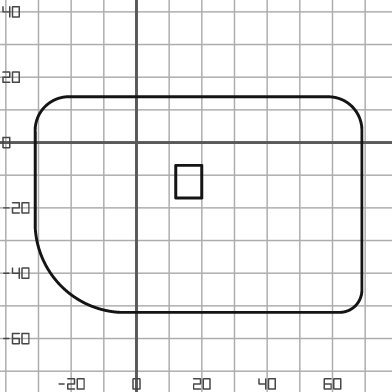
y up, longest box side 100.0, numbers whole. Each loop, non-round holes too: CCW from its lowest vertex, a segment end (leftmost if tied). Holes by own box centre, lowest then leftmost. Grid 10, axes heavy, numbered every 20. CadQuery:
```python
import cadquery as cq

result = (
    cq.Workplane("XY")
    .moveTo(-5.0, -52.0)
    .lineTo(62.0, -52.0)
    .threePointArc((67.0, -50.0), (69.0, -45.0))
    .lineTo(69.0, 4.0)
    .threePointArc((66.0, 11.0), (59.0, 14.0))
    .lineTo(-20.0, 14.0)
    .threePointArc((-28.0, 11.0), (-31.0, 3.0))
    .lineTo(-31.0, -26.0)
    .threePointArc((-23.0, -44.0), (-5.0, -52.0))
    .close()
    .moveTo(12.0, -17.0)
    .lineTo(20.0, -17.0)
    .lineTo(20.0, -7.0)
    .lineTo(12.0, -7.0)
    .close()
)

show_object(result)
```